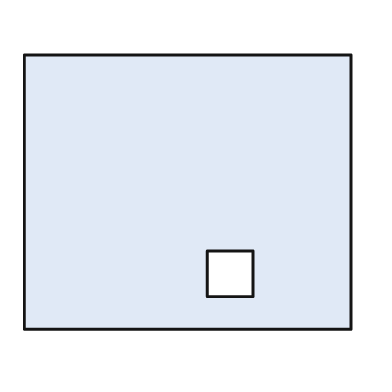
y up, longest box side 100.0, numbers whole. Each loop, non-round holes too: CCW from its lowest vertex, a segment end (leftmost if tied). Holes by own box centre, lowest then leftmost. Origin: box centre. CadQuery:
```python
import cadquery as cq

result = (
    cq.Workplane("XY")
    .moveTo(-50.0, -42.0)
    .lineTo(50.0, -42.0)
    .lineTo(50.0, 42.0)
    .lineTo(-50.0, 42.0)
    .close()
    .moveTo(6.0, -32.0)
    .lineTo(20.0, -32.0)
    .lineTo(20.0, -18.0)
    .lineTo(6.0, -18.0)
    .close()
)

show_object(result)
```